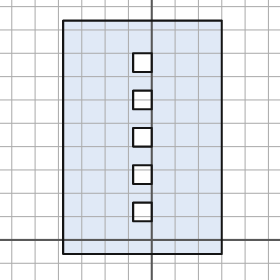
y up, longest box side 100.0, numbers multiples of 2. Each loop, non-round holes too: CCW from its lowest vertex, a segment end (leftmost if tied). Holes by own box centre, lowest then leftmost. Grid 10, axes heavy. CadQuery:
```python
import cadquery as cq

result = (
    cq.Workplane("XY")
    .moveTo(-38.0, -6.0)
    .lineTo(30.0, -6.0)
    .lineTo(30.0, 94.0)
    .lineTo(-38.0, 94.0)
    .close()
    .moveTo(-8.0, 8.0)
    .lineTo(0.0, 8.0)
    .lineTo(0.0, 16.0)
    .lineTo(-8.0, 16.0)
    .close()
    .moveTo(-8.0, 24.0)
    .lineTo(0.0, 24.0)
    .lineTo(0.0, 32.0)
    .lineTo(-8.0, 32.0)
    .close()
    .moveTo(-8.0, 40.0)
    .lineTo(0.0, 40.0)
    .lineTo(0.0, 48.0)
    .lineTo(-8.0, 48.0)
    .close()
    .moveTo(-8.0, 56.0)
    .lineTo(0.0, 56.0)
    .lineTo(0.0, 64.0)
    .lineTo(-8.0, 64.0)
    .close()
    .moveTo(-8.0, 72.0)
    .lineTo(0.0, 72.0)
    .lineTo(0.0, 80.0)
    .lineTo(-8.0, 80.0)
    .close()
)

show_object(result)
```